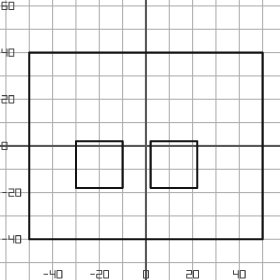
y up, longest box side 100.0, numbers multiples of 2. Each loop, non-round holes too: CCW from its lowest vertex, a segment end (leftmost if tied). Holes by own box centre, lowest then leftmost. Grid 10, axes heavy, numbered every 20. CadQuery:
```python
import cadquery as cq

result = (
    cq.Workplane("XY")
    .moveTo(-50.0, -40.0)
    .lineTo(50.0, -40.0)
    .lineTo(50.0, 40.0)
    .lineTo(-50.0, 40.0)
    .close()
    .moveTo(-30.0, -18.0)
    .lineTo(-10.0, -18.0)
    .lineTo(-10.0, 2.0)
    .lineTo(-30.0, 2.0)
    .close()
    .moveTo(2.0, -18.0)
    .lineTo(22.0, -18.0)
    .lineTo(22.0, 2.0)
    .lineTo(2.0, 2.0)
    .close()
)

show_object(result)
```